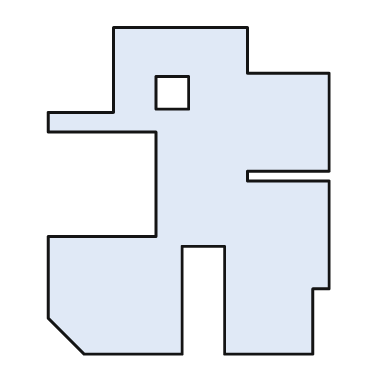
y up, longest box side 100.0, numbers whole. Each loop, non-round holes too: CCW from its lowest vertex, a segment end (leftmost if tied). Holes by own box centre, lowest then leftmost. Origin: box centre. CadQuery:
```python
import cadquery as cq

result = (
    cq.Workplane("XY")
    .moveTo(-32.0, -50.0)
    .lineTo(-2.0, -50.0)
    .lineTo(-2.0, -17.0)
    .lineTo(11.0, -17.0)
    .lineTo(11.0, -50.0)
    .lineTo(38.0, -50.0)
    .lineTo(38.0, -30.0)
    .lineTo(43.0, -30.0)
    .lineTo(43.0, 3.0)
    .lineTo(18.0, 3.0)
    .lineTo(18.0, 6.0)
    .lineTo(43.0, 6.0)
    .lineTo(43.0, 36.0)
    .lineTo(18.0, 36.0)
    .lineTo(18.0, 50.0)
    .lineTo(-23.0, 50.0)
    .lineTo(-23.0, 24.0)
    .lineTo(-43.0, 24.0)
    .lineTo(-43.0, 18.0)
    .lineTo(-10.0, 18.0)
    .lineTo(-10.0, -14.0)
    .lineTo(-43.0, -14.0)
    .lineTo(-43.0, -39.0)
    .close()
    .moveTo(-10.0, 25.0)
    .lineTo(0.0, 25.0)
    .lineTo(0.0, 35.0)
    .lineTo(-10.0, 35.0)
    .close()
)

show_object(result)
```